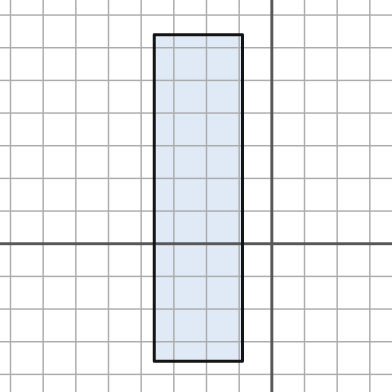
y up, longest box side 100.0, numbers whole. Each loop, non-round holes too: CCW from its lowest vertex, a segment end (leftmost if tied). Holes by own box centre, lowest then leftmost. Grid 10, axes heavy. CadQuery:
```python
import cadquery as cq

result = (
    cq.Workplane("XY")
    .moveTo(-36.0, -36.0)
    .lineTo(-9.0, -36.0)
    .lineTo(-9.0, 64.0)
    .lineTo(-36.0, 64.0)
    .close()
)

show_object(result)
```